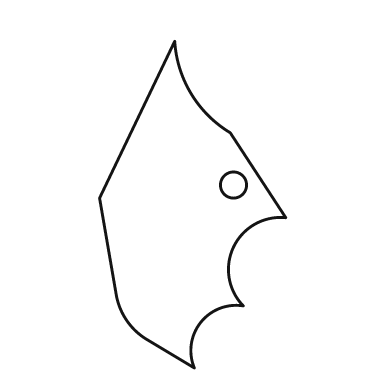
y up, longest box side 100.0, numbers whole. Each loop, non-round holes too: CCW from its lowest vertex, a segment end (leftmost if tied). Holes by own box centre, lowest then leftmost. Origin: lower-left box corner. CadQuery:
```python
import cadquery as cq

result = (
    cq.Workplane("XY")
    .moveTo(29.0, 0.0)
    .threePointArc((31.0, 14.0), (44.0, 19.0))
    .threePointArc((41.0, 37.0), (57.0, 46.0))
    .lineTo(40.0, 72.0)
    .threePointArc((28.0, 84.0), (23.0, 100.0))
    .lineTo(0.0, 52.0)
    .lineTo(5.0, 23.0)
    .threePointArc((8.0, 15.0), (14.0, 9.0))
    .close()
    .moveTo(41.0, 56.0)
    .circle(4.0)
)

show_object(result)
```